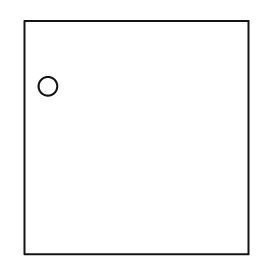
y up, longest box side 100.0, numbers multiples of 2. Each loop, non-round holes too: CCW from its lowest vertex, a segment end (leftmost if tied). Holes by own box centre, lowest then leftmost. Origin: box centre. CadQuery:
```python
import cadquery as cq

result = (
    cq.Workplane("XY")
    .moveTo(-48.0, -50.0)
    .lineTo(48.0, -50.0)
    .lineTo(48.0, 50.0)
    .lineTo(-48.0, 50.0)
    .close()
    .moveTo(-38.0, 22.0)
    .circle(4.0)
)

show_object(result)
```